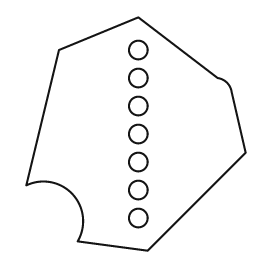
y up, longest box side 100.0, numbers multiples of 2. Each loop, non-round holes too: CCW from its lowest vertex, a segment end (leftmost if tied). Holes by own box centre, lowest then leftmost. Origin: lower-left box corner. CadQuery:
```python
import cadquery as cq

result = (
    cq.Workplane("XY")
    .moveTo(52.0, 0.0)
    .lineTo(94.0, 42.0)
    .lineTo(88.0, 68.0)
    .threePointArc((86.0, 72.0), (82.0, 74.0))
    .lineTo(48.0, 100.0)
    .lineTo(14.0, 86.0)
    .lineTo(0.0, 28.0)
    .threePointArc((20.0, 24.0), (22.0, 4.0))
    .close()
    .moveTo(48.0, 14.0)
    .circle(4.0)
    .moveTo(48.0, 26.0)
    .circle(4.0)
    .moveTo(48.0, 38.0)
    .circle(4.0)
    .moveTo(48.0, 50.0)
    .circle(4.0)
    .moveTo(48.0, 62.0)
    .circle(4.0)
    .moveTo(48.0, 74.0)
    .circle(4.0)
    .moveTo(48.0, 86.0)
    .circle(4.0)
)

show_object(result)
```